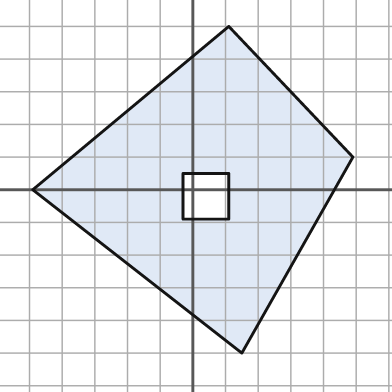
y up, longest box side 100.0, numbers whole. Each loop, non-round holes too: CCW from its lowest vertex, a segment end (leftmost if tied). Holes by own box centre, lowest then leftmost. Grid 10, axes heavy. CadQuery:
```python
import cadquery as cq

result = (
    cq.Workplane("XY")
    .moveTo(15.0, -50.0)
    .lineTo(49.0, 10.0)
    .lineTo(11.0, 50.0)
    .lineTo(-49.0, 0.0)
    .close()
    .moveTo(-3.0, -9.0)
    .lineTo(11.0, -9.0)
    .lineTo(11.0, 5.0)
    .lineTo(-3.0, 5.0)
    .close()
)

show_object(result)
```